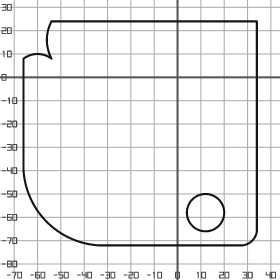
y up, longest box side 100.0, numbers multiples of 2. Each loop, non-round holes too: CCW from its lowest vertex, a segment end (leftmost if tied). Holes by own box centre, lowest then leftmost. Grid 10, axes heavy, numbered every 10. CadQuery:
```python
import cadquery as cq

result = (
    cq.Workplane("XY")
    .moveTo(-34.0, -72.0)
    .lineTo(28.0, -72.0)
    .threePointArc((32.0, -70.0), (34.0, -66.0))
    .lineTo(34.0, 24.0)
    .lineTo(-54.0, 24.0)
    .threePointArc((-56.0, 16.0), (-54.0, 8.0))
    .threePointArc((-60.0, 10.0), (-66.0, 8.0))
    .lineTo(-66.0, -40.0)
    .threePointArc((-56.0, -62.0), (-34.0, -72.0))
    .close()
    .moveTo(12.0, -58.0)
    .circle(8.0)
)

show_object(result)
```